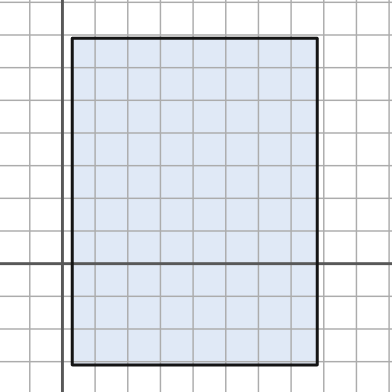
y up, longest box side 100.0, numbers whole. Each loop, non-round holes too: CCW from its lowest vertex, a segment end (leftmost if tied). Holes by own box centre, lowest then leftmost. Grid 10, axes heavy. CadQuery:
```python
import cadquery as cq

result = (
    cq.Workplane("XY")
    .moveTo(3.0, -31.0)
    .lineTo(78.0, -31.0)
    .lineTo(78.0, 69.0)
    .lineTo(3.0, 69.0)
    .close()
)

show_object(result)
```